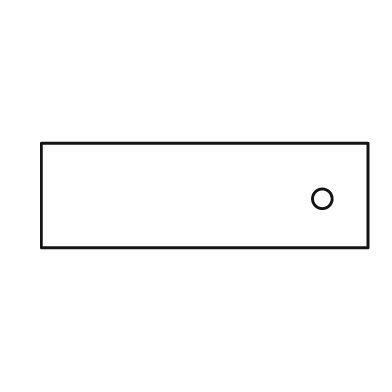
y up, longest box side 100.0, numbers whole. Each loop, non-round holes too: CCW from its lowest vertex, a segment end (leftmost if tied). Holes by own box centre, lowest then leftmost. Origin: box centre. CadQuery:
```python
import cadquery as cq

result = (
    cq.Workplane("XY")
    .moveTo(-50.0, -16.0)
    .lineTo(50.0, -16.0)
    .lineTo(50.0, 16.0)
    .lineTo(-50.0, 16.0)
    .close()
    .moveTo(36.0, -1.0)
    .circle(3.0)
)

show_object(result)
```